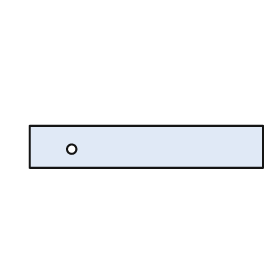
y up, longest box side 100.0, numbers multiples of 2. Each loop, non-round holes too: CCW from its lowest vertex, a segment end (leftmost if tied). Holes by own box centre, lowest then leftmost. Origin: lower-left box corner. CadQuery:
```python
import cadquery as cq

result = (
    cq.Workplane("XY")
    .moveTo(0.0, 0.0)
    .lineTo(100.0, 0.0)
    .lineTo(100.0, 18.0)
    .lineTo(0.0, 18.0)
    .close()
    .moveTo(18.0, 8.0)
    .circle(2.0)
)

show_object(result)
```